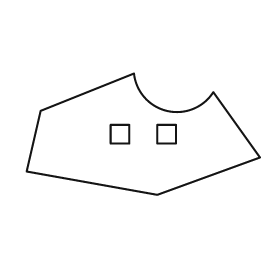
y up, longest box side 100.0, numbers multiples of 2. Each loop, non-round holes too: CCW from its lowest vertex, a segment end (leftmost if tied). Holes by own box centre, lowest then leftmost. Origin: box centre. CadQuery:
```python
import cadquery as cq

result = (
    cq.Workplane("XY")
    .moveTo(6.0, -26.0)
    .lineTo(50.0, -10.0)
    .lineTo(30.0, 18.0)
    .threePointArc((10.0, 10.0), (-4.0, 26.0))
    .lineTo(-44.0, 10.0)
    .lineTo(-50.0, -16.0)
    .close()
    .moveTo(-14.0, -4.0)
    .lineTo(-6.0, -4.0)
    .lineTo(-6.0, 4.0)
    .lineTo(-14.0, 4.0)
    .close()
    .moveTo(6.0, -4.0)
    .lineTo(14.0, -4.0)
    .lineTo(14.0, 4.0)
    .lineTo(6.0, 4.0)
    .close()
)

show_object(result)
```